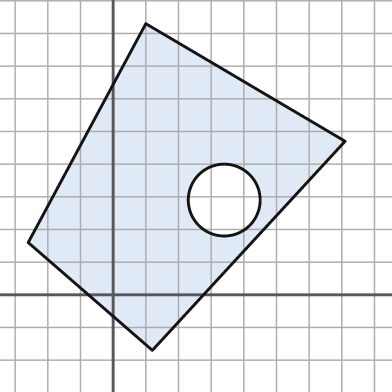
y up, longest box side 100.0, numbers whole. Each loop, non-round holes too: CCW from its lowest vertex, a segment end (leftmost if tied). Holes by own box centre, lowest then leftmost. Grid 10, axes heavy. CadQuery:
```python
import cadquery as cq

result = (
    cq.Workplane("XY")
    .moveTo(12.0, -17.0)
    .lineTo(71.0, 47.0)
    .lineTo(10.0, 83.0)
    .lineTo(-26.0, 16.0)
    .close()
    .moveTo(34.0, 29.0)
    .circle(11.0)
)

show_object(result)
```